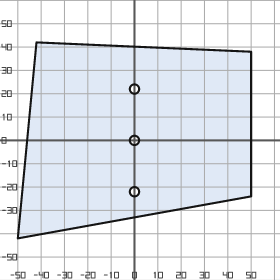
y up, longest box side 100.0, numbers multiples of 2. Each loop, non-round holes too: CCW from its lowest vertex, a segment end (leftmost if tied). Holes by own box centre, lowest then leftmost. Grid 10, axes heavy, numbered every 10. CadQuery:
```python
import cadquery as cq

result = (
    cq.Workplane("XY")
    .moveTo(-50.0, -42.0)
    .lineTo(50.0, -24.0)
    .lineTo(50.0, 38.0)
    .lineTo(-42.0, 42.0)
    .close()
    .moveTo(0.0, -22.0)
    .circle(2.0)
    .moveTo(0.0, 0.0)
    .circle(2.0)
    .moveTo(0.0, 22.0)
    .circle(2.0)
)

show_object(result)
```